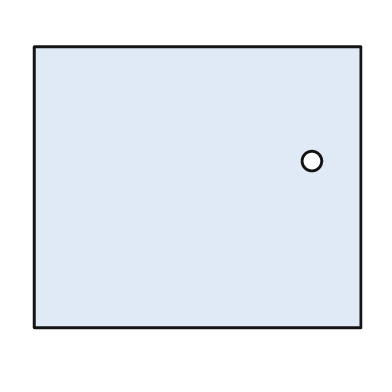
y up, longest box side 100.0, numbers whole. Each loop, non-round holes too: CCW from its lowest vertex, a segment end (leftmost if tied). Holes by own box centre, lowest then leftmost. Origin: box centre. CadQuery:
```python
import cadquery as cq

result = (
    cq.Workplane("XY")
    .moveTo(-50.0, -43.0)
    .lineTo(50.0, -43.0)
    .lineTo(50.0, 43.0)
    .lineTo(-50.0, 43.0)
    .close()
    .moveTo(35.0, 8.0)
    .circle(3.0)
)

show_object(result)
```